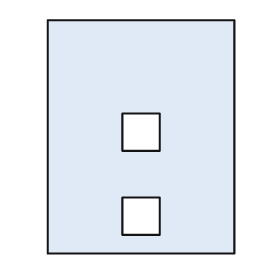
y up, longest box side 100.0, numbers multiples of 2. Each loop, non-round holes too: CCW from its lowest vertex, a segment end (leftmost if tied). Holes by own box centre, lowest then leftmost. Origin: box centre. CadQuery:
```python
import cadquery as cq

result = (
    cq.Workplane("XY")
    .moveTo(-40.0, -50.0)
    .lineTo(40.0, -50.0)
    .lineTo(40.0, 50.0)
    .lineTo(-40.0, 50.0)
    .close()
    .moveTo(-8.0, -42.0)
    .lineTo(8.0, -42.0)
    .lineTo(8.0, -26.0)
    .lineTo(-8.0, -26.0)
    .close()
    .moveTo(-8.0, -6.0)
    .lineTo(8.0, -6.0)
    .lineTo(8.0, 10.0)
    .lineTo(-8.0, 10.0)
    .close()
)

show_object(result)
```